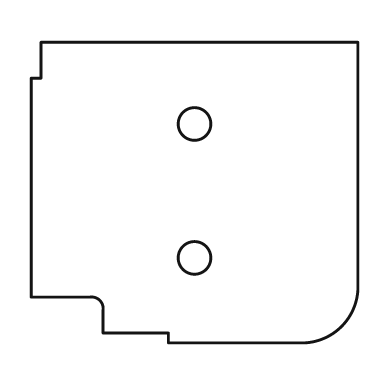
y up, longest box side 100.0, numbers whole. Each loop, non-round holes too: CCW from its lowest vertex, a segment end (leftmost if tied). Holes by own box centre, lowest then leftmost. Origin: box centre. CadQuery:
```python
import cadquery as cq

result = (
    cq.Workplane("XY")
    .moveTo(-8.0, -46.0)
    .lineTo(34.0, -46.0)
    .threePointArc((45.0, -41.0), (50.0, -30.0))
    .lineTo(50.0, 46.0)
    .lineTo(-47.0, 46.0)
    .lineTo(-47.0, 35.0)
    .lineTo(-50.0, 35.0)
    .lineTo(-50.0, -32.0)
    .lineTo(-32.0, -32.0)
    .threePointArc((-29.0, -33.0), (-28.0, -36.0))
    .lineTo(-28.0, -43.0)
    .lineTo(-8.0, -43.0)
    .close()
    .moveTo(0.0, -20.0)
    .circle(5.0)
    .moveTo(0.0, 21.0)
    .circle(5.0)
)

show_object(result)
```